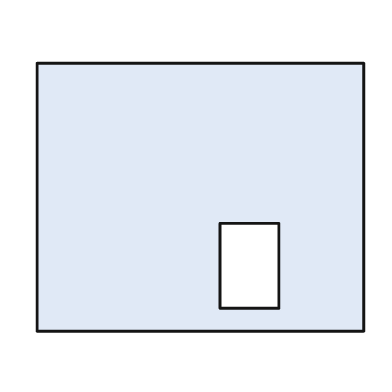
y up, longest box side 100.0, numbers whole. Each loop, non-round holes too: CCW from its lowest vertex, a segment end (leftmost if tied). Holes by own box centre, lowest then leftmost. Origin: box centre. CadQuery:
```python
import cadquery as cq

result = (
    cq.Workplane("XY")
    .moveTo(-50.0, -41.0)
    .lineTo(50.0, -41.0)
    .lineTo(50.0, 41.0)
    .lineTo(-50.0, 41.0)
    .close()
    .moveTo(6.0, -34.0)
    .lineTo(24.0, -34.0)
    .lineTo(24.0, -8.0)
    .lineTo(6.0, -8.0)
    .close()
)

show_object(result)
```